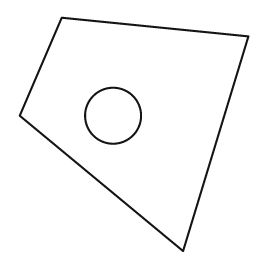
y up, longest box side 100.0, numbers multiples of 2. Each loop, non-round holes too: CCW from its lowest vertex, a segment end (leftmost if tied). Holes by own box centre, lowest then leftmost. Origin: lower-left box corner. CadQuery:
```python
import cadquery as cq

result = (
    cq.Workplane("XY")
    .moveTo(70.0, 0.0)
    .lineTo(98.0, 92.0)
    .lineTo(18.0, 100.0)
    .lineTo(0.0, 58.0)
    .close()
    .moveTo(40.0, 58.0)
    .circle(12.0)
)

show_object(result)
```